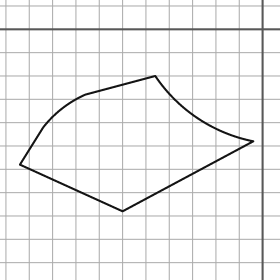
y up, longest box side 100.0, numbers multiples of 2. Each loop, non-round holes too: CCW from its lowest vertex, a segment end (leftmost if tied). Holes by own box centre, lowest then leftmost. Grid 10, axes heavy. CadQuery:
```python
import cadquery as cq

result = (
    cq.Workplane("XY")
    .moveTo(-60.0, -78.0)
    .lineTo(-4.0, -48.0)
    .threePointArc((-28.0, -38.0), (-46.0, -20.0))
    .lineTo(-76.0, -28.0)
    .threePointArc((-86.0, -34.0), (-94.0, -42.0))
    .lineTo(-104.0, -58.0)
    .close()
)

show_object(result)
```